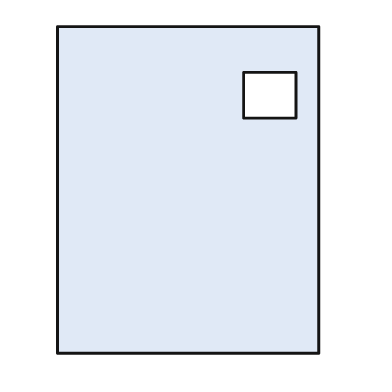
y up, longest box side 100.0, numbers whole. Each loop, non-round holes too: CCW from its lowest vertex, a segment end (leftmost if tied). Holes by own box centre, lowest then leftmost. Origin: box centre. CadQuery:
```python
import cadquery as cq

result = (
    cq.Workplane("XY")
    .moveTo(-40.0, -50.0)
    .lineTo(40.0, -50.0)
    .lineTo(40.0, 50.0)
    .lineTo(-40.0, 50.0)
    .close()
    .moveTo(17.0, 22.0)
    .lineTo(33.0, 22.0)
    .lineTo(33.0, 36.0)
    .lineTo(17.0, 36.0)
    .close()
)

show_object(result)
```